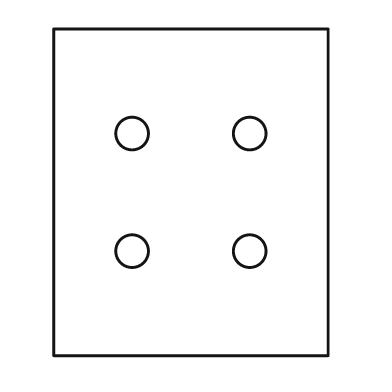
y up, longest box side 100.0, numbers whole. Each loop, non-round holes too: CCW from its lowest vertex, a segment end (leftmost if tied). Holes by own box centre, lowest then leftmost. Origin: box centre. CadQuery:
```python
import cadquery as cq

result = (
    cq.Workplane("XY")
    .moveTo(-42.0, -50.0)
    .lineTo(42.0, -50.0)
    .lineTo(42.0, 50.0)
    .lineTo(-42.0, 50.0)
    .close()
    .moveTo(-18.0, -18.0)
    .circle(5.0)
    .moveTo(18.0, -18.0)
    .circle(5.0)
    .moveTo(-18.0, 18.0)
    .circle(5.0)
    .moveTo(18.0, 18.0)
    .circle(5.0)
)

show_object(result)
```